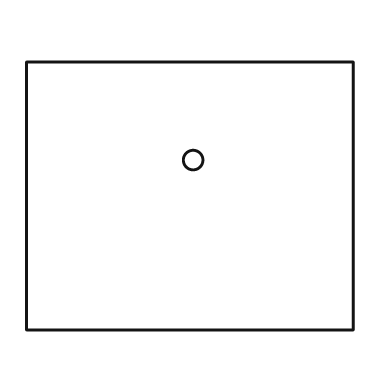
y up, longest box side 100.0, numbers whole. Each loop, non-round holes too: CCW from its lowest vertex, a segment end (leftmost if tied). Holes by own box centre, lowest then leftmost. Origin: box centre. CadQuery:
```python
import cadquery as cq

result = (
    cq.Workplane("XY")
    .moveTo(-50.0, -41.0)
    .lineTo(50.0, -41.0)
    .lineTo(50.0, 41.0)
    .lineTo(-50.0, 41.0)
    .close()
    .moveTo(1.0, 11.0)
    .circle(3.0)
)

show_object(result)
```